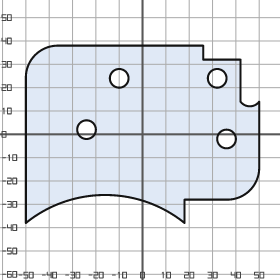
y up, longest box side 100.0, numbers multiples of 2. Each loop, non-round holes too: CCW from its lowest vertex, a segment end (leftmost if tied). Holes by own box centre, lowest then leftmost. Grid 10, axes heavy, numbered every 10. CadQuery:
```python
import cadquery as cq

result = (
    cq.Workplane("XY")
    .moveTo(-50.0, -38.0)
    .threePointArc((-16.0, -26.0), (18.0, -38.0))
    .lineTo(18.0, -28.0)
    .lineTo(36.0, -28.0)
    .threePointArc((46.0, -24.0), (50.0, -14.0))
    .lineTo(50.0, 14.0)
    .threePointArc((46.0, 12.0), (42.0, 14.0))
    .lineTo(42.0, 32.0)
    .lineTo(26.0, 32.0)
    .lineTo(26.0, 38.0)
    .lineTo(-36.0, 38.0)
    .threePointArc((-46.0, 34.0), (-50.0, 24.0))
    .close()
    .moveTo(36.0, -2.0)
    .circle(4.0)
    .moveTo(-24.0, 2.0)
    .circle(4.0)
    .moveTo(-10.0, 24.0)
    .circle(4.0)
    .moveTo(32.0, 24.0)
    .circle(4.0)
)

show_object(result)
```